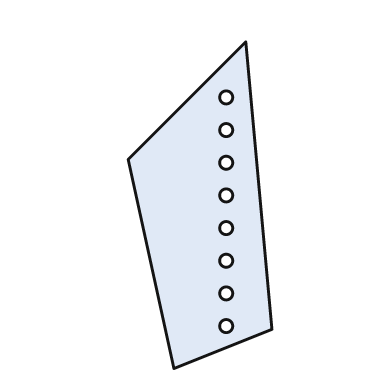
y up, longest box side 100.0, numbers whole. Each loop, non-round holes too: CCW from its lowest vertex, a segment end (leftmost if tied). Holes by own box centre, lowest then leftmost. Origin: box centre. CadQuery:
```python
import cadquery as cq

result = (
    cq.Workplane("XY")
    .moveTo(-8.0, -50.0)
    .lineTo(22.0, -38.0)
    .lineTo(14.0, 50.0)
    .lineTo(-22.0, 14.0)
    .close()
    .moveTo(8.0, -37.0)
    .circle(2.0)
    .moveTo(8.0, -27.0)
    .circle(2.0)
    .moveTo(8.0, -17.0)
    .circle(2.0)
    .moveTo(8.0, -7.0)
    .circle(2.0)
    .moveTo(8.0, 3.0)
    .circle(2.0)
    .moveTo(8.0, 13.0)
    .circle(2.0)
    .moveTo(8.0, 23.0)
    .circle(2.0)
    .moveTo(8.0, 33.0)
    .circle(2.0)
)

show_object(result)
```